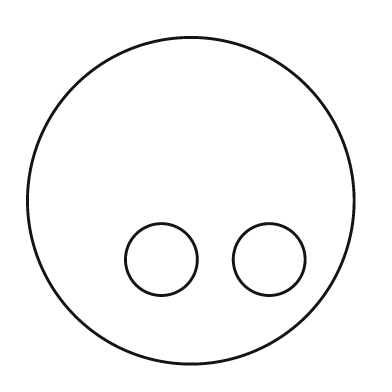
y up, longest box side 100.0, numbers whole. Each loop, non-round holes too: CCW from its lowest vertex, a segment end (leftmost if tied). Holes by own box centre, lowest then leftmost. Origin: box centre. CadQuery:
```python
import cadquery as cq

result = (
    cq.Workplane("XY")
    .moveTo(0.0, 0.0)
    .circle(50.0)
    .moveTo(-9.0, -18.0)
    .circle(11.0)
    .moveTo(24.0, -18.0)
    .circle(11.0)
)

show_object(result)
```